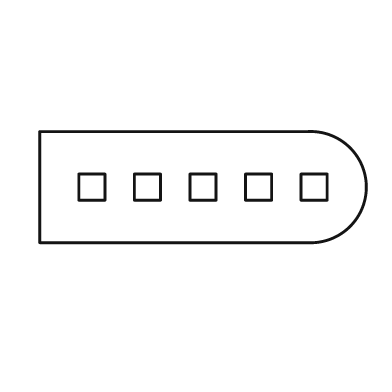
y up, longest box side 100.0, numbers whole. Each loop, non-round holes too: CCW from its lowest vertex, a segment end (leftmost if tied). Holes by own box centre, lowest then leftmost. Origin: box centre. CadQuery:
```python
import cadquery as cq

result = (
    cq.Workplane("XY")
    .moveTo(-50.0, -17.0)
    .lineTo(32.0, -17.0)
    .threePointArc((50.0, 0.0), (32.0, 17.0))
    .lineTo(-50.0, 17.0)
    .close()
    .moveTo(-38.0, -4.0)
    .lineTo(-30.0, -4.0)
    .lineTo(-30.0, 4.0)
    .lineTo(-38.0, 4.0)
    .close()
    .moveTo(-21.0, -4.0)
    .lineTo(-13.0, -4.0)
    .lineTo(-13.0, 4.0)
    .lineTo(-21.0, 4.0)
    .close()
    .moveTo(-4.0, -4.0)
    .lineTo(4.0, -4.0)
    .lineTo(4.0, 4.0)
    .lineTo(-4.0, 4.0)
    .close()
    .moveTo(13.0, -4.0)
    .lineTo(21.0, -4.0)
    .lineTo(21.0, 4.0)
    .lineTo(13.0, 4.0)
    .close()
    .moveTo(30.0, -4.0)
    .lineTo(38.0, -4.0)
    .lineTo(38.0, 4.0)
    .lineTo(30.0, 4.0)
    .close()
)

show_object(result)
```